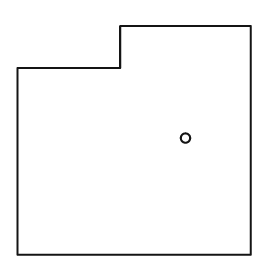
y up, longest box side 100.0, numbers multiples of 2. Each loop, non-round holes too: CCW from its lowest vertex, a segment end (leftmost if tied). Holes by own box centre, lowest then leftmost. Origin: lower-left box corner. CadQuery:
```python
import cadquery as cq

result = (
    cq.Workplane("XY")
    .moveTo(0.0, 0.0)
    .lineTo(100.0, 0.0)
    .lineTo(100.0, 98.0)
    .lineTo(44.0, 98.0)
    .lineTo(44.0, 80.0)
    .lineTo(0.0, 80.0)
    .close()
    .moveTo(72.0, 50.0)
    .circle(2.0)
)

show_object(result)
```